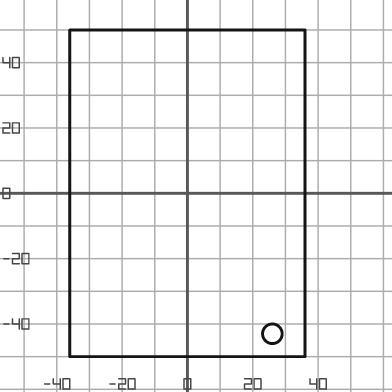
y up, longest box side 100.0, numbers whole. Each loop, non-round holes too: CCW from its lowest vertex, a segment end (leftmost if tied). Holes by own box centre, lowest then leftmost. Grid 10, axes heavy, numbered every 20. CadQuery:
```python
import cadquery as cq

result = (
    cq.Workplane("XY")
    .moveTo(-36.0, -50.0)
    .lineTo(36.0, -50.0)
    .lineTo(36.0, 50.0)
    .lineTo(-36.0, 50.0)
    .close()
    .moveTo(26.0, -43.0)
    .circle(3.0)
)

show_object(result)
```